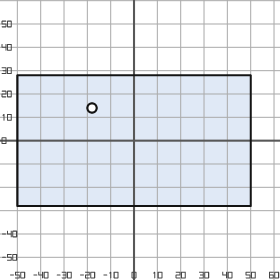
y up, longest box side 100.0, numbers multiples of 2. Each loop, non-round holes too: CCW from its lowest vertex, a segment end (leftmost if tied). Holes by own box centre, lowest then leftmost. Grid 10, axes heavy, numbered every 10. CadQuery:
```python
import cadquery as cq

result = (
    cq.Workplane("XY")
    .moveTo(-50.0, -28.0)
    .lineTo(50.0, -28.0)
    .lineTo(50.0, 28.0)
    .lineTo(-50.0, 28.0)
    .close()
    .moveTo(-18.0, 14.0)
    .circle(2.0)
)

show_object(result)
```